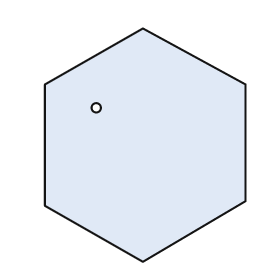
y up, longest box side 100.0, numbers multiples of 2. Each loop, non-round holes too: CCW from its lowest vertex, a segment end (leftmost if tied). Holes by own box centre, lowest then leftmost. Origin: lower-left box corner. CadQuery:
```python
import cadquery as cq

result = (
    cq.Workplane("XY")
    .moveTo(42.0, 0.0)
    .lineTo(86.0, 26.0)
    .lineTo(86.0, 76.0)
    .lineTo(42.0, 100.0)
    .lineTo(0.0, 76.0)
    .lineTo(0.0, 24.0)
    .close()
    .moveTo(22.0, 66.0)
    .circle(2.0)
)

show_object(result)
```